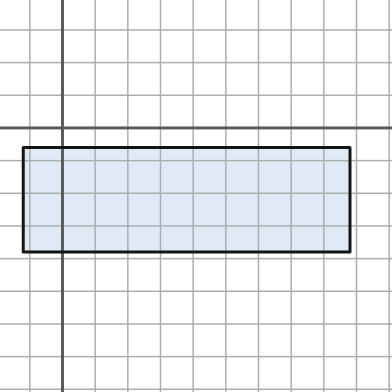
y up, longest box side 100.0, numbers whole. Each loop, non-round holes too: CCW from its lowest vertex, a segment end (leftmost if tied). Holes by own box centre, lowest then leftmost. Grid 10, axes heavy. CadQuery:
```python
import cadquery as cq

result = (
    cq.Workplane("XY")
    .moveTo(-12.0, -38.0)
    .lineTo(88.0, -38.0)
    .lineTo(88.0, -6.0)
    .lineTo(-12.0, -6.0)
    .close()
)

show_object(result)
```